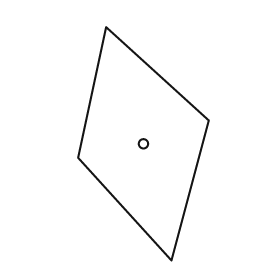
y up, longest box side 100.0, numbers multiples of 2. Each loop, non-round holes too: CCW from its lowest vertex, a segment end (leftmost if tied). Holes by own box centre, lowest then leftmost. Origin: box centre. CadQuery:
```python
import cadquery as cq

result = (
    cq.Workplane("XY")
    .moveTo(12.0, -50.0)
    .lineTo(28.0, 10.0)
    .lineTo(-16.0, 50.0)
    .lineTo(-28.0, -6.0)
    .close()
    .moveTo(0.0, 0.0)
    .circle(2.0)
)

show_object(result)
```